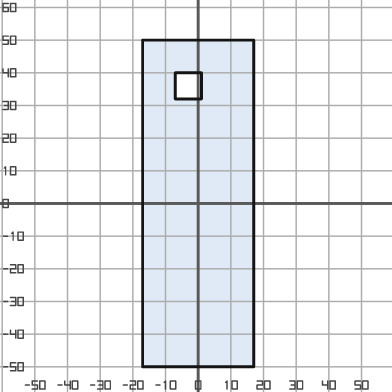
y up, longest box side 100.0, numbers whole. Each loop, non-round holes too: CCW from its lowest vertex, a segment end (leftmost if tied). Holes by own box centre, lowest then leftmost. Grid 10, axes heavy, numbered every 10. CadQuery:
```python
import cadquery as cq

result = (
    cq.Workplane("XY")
    .moveTo(-17.0, -50.0)
    .lineTo(17.0, -50.0)
    .lineTo(17.0, 50.0)
    .lineTo(-17.0, 50.0)
    .close()
    .moveTo(-7.0, 32.0)
    .lineTo(1.0, 32.0)
    .lineTo(1.0, 40.0)
    .lineTo(-7.0, 40.0)
    .close()
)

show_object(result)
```